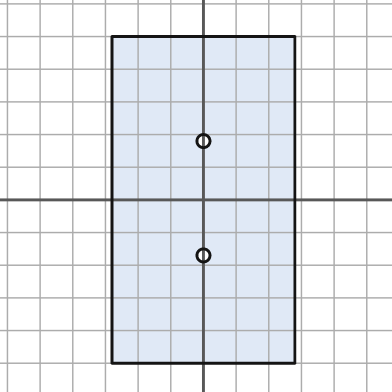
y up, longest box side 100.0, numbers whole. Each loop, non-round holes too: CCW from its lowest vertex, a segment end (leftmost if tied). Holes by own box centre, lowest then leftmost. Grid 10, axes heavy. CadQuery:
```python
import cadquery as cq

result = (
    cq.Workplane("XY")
    .moveTo(-28.0, -50.0)
    .lineTo(28.0, -50.0)
    .lineTo(28.0, 50.0)
    .lineTo(-28.0, 50.0)
    .close()
    .moveTo(0.0, -17.0)
    .circle(2.0)
    .moveTo(0.0, 18.0)
    .circle(2.0)
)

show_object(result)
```